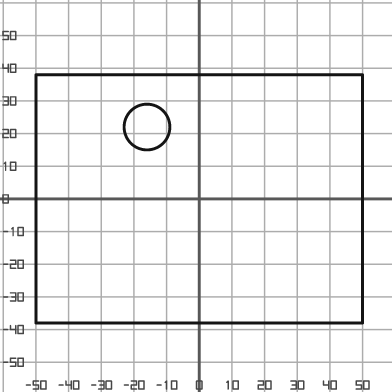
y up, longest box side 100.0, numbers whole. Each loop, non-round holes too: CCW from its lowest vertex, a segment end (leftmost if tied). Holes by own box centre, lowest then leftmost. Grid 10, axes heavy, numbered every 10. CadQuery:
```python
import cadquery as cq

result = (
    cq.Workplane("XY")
    .moveTo(-50.0, -38.0)
    .lineTo(50.0, -38.0)
    .lineTo(50.0, 38.0)
    .lineTo(-50.0, 38.0)
    .close()
    .moveTo(-16.0, 22.0)
    .circle(7.0)
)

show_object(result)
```